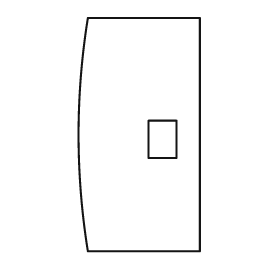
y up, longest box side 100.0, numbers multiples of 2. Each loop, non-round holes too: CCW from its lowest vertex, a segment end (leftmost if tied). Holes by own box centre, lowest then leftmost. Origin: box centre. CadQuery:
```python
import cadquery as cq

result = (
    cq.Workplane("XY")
    .moveTo(-22.0, -50.0)
    .lineTo(26.0, -50.0)
    .lineTo(26.0, 50.0)
    .lineTo(-22.0, 50.0)
    .threePointArc((-26.0, 0.0), (-22.0, -50.0))
    .close()
    .moveTo(4.0, -10.0)
    .lineTo(16.0, -10.0)
    .lineTo(16.0, 6.0)
    .lineTo(4.0, 6.0)
    .close()
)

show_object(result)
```